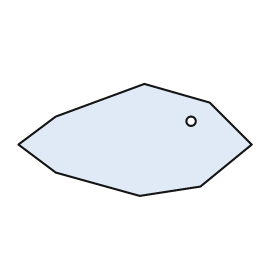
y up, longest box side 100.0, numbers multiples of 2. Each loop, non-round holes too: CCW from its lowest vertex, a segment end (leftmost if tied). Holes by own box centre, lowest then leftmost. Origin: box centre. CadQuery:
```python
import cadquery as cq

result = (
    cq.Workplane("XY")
    .moveTo(2.0, -24.0)
    .lineTo(28.0, -20.0)
    .lineTo(50.0, -2.0)
    .lineTo(32.0, 16.0)
    .lineTo(4.0, 24.0)
    .lineTo(-34.0, 10.0)
    .lineTo(-50.0, -2.0)
    .lineTo(-34.0, -14.0)
    .close()
    .moveTo(24.0, 8.0)
    .circle(2.0)
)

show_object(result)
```